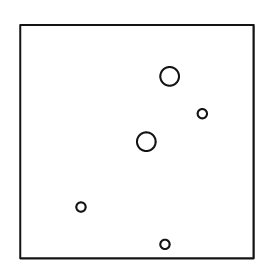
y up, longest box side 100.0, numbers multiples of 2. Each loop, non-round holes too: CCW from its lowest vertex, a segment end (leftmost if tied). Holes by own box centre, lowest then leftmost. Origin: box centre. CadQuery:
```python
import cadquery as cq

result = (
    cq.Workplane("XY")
    .moveTo(-50.0, -50.0)
    .lineTo(50.0, -50.0)
    .lineTo(50.0, 50.0)
    .lineTo(-50.0, 50.0)
    .close()
    .moveTo(12.0, -44.0)
    .circle(2.0)
    .moveTo(-24.0, -28.0)
    .circle(2.0)
    .moveTo(4.0, 0.0)
    .circle(4.0)
    .moveTo(28.0, 12.0)
    .circle(2.0)
    .moveTo(14.0, 28.0)
    .circle(4.0)
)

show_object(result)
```